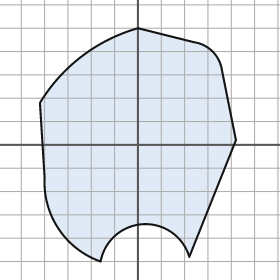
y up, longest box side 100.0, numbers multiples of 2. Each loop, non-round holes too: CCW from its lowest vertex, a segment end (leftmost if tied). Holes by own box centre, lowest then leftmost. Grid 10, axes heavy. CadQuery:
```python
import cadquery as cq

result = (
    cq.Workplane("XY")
    .moveTo(-16.0, -50.0)
    .threePointArc((2.0, -34.0), (22.0, -48.0))
    .lineTo(42.0, 2.0)
    .lineTo(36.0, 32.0)
    .threePointArc((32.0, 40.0), (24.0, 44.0))
    .lineTo(0.0, 50.0)
    .threePointArc((-24.0, 38.0), (-42.0, 18.0))
    .lineTo(-40.0, -14.0)
    .threePointArc((-34.0, -36.0), (-16.0, -50.0))
    .close()
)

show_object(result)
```